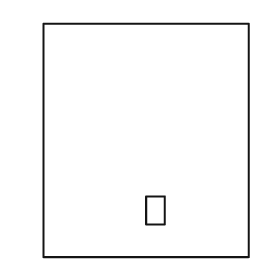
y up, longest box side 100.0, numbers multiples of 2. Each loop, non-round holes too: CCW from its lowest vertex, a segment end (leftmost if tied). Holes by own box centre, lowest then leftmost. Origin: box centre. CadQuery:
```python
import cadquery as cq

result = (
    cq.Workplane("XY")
    .moveTo(-44.0, -50.0)
    .lineTo(44.0, -50.0)
    .lineTo(44.0, 50.0)
    .lineTo(-44.0, 50.0)
    .close()
    .moveTo(0.0, -36.0)
    .lineTo(8.0, -36.0)
    .lineTo(8.0, -24.0)
    .lineTo(0.0, -24.0)
    .close()
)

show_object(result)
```